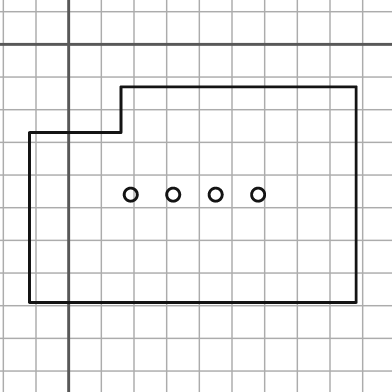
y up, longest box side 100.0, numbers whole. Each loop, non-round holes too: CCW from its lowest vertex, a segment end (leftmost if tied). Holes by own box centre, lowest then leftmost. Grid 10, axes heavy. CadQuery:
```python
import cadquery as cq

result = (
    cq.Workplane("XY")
    .moveTo(-12.0, -79.0)
    .lineTo(88.0, -79.0)
    .lineTo(88.0, -13.0)
    .lineTo(16.0, -13.0)
    .lineTo(16.0, -27.0)
    .lineTo(-12.0, -27.0)
    .close()
    .moveTo(19.0, -46.0)
    .circle(2.0)
    .moveTo(32.0, -46.0)
    .circle(2.0)
    .moveTo(45.0, -46.0)
    .circle(2.0)
    .moveTo(58.0, -46.0)
    .circle(2.0)
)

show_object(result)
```